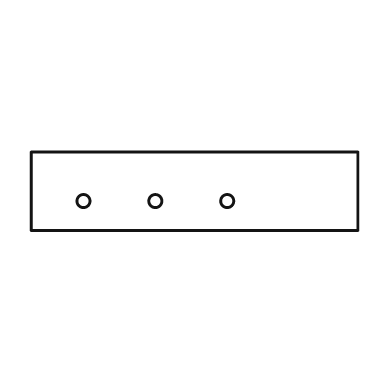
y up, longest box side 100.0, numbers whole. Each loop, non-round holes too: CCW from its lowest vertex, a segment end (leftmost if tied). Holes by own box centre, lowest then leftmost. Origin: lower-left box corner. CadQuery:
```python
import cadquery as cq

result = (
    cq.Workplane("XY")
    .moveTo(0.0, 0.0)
    .lineTo(100.0, 0.0)
    .lineTo(100.0, 24.0)
    .lineTo(0.0, 24.0)
    .close()
    .moveTo(16.0, 9.0)
    .circle(2.0)
    .moveTo(38.0, 9.0)
    .circle(2.0)
    .moveTo(60.0, 9.0)
    .circle(2.0)
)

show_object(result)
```